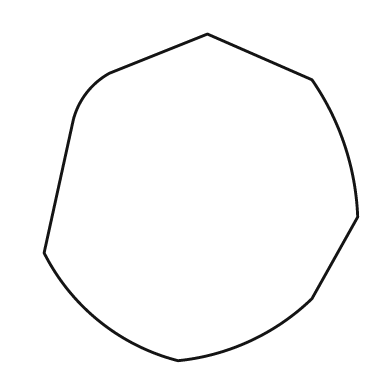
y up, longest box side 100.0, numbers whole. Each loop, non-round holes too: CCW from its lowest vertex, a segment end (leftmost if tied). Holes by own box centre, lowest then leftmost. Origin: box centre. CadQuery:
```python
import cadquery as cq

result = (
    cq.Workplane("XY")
    .moveTo(-7.0, -50.0)
    .threePointArc((15.0, -44.0), (34.0, -31.0))
    .lineTo(48.0, -6.0)
    .threePointArc((44.0, 16.0), (34.0, 36.0))
    .lineTo(2.0, 50.0)
    .lineTo(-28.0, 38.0)
    .threePointArc((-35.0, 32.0), (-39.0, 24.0))
    .lineTo(-48.0, -17.0)
    .threePointArc((-31.0, -38.0), (-7.0, -50.0))
    .close()
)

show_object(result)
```